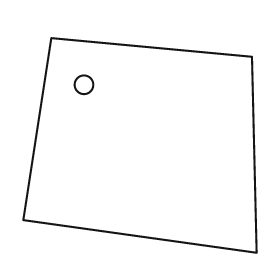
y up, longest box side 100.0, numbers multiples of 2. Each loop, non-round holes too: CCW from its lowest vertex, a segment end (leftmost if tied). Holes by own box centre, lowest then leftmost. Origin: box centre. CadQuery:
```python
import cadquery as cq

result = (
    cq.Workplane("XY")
    .moveTo(50.0, -46.0)
    .lineTo(48.0, 38.0)
    .lineTo(-38.0, 46.0)
    .lineTo(-50.0, -32.0)
    .close()
    .moveTo(-24.0, 26.0)
    .circle(4.0)
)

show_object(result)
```